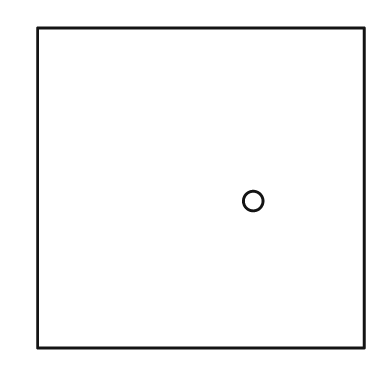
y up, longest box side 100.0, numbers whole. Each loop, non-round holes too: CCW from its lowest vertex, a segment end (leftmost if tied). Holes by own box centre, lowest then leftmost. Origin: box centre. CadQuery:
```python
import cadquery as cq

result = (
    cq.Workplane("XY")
    .moveTo(-50.0, -49.0)
    .lineTo(50.0, -49.0)
    .lineTo(50.0, 49.0)
    .lineTo(-50.0, 49.0)
    .close()
    .moveTo(16.0, -4.0)
    .circle(3.0)
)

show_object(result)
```